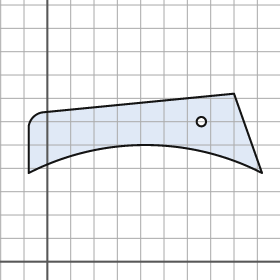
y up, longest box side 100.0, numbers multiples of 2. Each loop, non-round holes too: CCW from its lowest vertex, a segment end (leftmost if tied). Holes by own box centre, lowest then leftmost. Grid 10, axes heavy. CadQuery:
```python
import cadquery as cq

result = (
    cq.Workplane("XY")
    .moveTo(-8.0, 38.0)
    .threePointArc((42.0, 50.0), (92.0, 38.0))
    .lineTo(80.0, 72.0)
    .lineTo(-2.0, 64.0)
    .threePointArc((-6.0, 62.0), (-8.0, 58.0))
    .close()
    .moveTo(66.0, 60.0)
    .circle(2.0)
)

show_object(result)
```